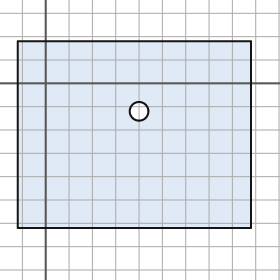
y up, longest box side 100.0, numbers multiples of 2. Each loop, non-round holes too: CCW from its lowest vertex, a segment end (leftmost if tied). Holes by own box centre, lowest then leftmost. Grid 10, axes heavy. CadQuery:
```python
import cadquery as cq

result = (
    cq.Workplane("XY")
    .moveTo(-12.0, -62.0)
    .lineTo(88.0, -62.0)
    .lineTo(88.0, 18.0)
    .lineTo(-12.0, 18.0)
    .close()
    .moveTo(40.0, -12.0)
    .circle(4.0)
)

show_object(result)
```